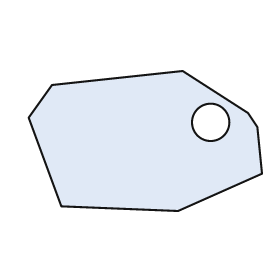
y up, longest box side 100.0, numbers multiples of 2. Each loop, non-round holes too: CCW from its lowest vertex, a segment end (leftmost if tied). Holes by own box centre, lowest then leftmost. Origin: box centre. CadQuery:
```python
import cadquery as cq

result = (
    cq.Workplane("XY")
    .moveTo(14.0, -30.0)
    .lineTo(50.0, -14.0)
    .lineTo(48.0, 6.0)
    .lineTo(44.0, 12.0)
    .lineTo(16.0, 30.0)
    .lineTo(-40.0, 24.0)
    .lineTo(-50.0, 10.0)
    .lineTo(-36.0, -28.0)
    .close()
    .moveTo(28.0, 8.0)
    .circle(8.0)
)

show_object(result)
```